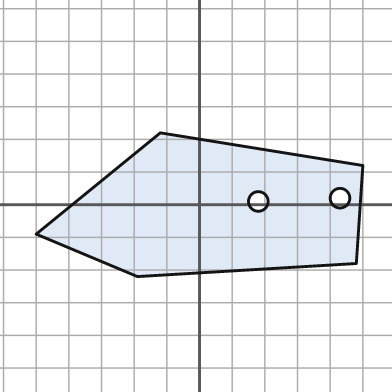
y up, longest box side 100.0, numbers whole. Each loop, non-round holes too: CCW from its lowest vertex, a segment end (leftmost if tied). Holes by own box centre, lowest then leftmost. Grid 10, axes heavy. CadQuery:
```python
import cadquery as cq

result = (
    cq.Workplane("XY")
    .moveTo(-19.0, -22.0)
    .lineTo(48.0, -18.0)
    .lineTo(50.0, 12.0)
    .lineTo(-12.0, 22.0)
    .lineTo(-50.0, -9.0)
    .close()
    .moveTo(18.0, 1.0)
    .circle(3.0)
    .moveTo(43.0, 2.0)
    .circle(3.0)
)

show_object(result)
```